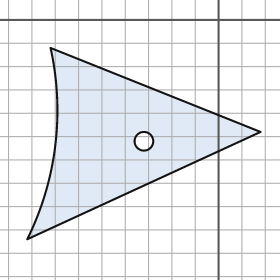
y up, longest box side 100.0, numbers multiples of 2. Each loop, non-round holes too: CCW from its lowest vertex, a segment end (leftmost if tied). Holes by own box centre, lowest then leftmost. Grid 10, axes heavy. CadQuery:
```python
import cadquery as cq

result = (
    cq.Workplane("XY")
    .moveTo(-82.0, -94.0)
    .lineTo(18.0, -48.0)
    .lineTo(-72.0, -12.0)
    .threePointArc((-70.0, -54.0), (-82.0, -94.0))
    .close()
    .moveTo(-32.0, -52.0)
    .circle(4.0)
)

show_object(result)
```